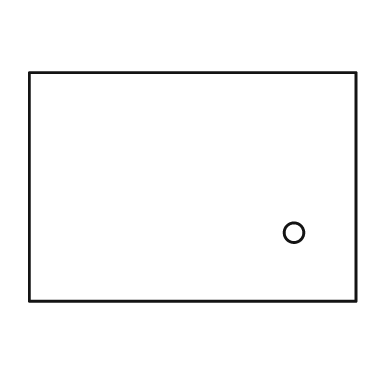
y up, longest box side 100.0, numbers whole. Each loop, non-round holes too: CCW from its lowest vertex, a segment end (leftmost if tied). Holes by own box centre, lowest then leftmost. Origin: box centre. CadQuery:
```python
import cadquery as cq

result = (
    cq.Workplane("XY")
    .moveTo(-50.0, -35.0)
    .lineTo(50.0, -35.0)
    .lineTo(50.0, 35.0)
    .lineTo(-50.0, 35.0)
    .close()
    .moveTo(31.0, -14.0)
    .circle(3.0)
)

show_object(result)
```